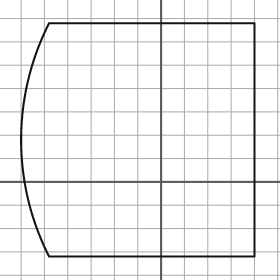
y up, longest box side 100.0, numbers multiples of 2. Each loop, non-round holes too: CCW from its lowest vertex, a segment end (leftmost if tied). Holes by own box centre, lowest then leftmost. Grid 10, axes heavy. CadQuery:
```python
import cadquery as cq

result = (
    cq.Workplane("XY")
    .moveTo(-48.0, -32.0)
    .lineTo(40.0, -32.0)
    .lineTo(40.0, 68.0)
    .lineTo(-48.0, 68.0)
    .threePointArc((-60.0, 18.0), (-48.0, -32.0))
    .close()
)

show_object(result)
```